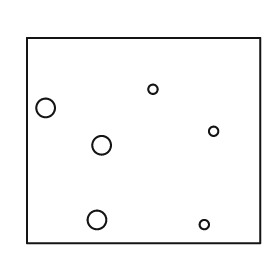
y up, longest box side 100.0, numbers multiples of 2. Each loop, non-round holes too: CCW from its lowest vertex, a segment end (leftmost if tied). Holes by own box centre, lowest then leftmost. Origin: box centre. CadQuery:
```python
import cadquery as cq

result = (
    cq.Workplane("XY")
    .moveTo(-50.0, -44.0)
    .lineTo(50.0, -44.0)
    .lineTo(50.0, 44.0)
    .lineTo(-50.0, 44.0)
    .close()
    .moveTo(26.0, -36.0)
    .circle(2.0)
    .moveTo(-20.0, -34.0)
    .circle(4.0)
    .moveTo(-18.0, -2.0)
    .circle(4.0)
    .moveTo(30.0, 4.0)
    .circle(2.0)
    .moveTo(-42.0, 14.0)
    .circle(4.0)
    .moveTo(4.0, 22.0)
    .circle(2.0)
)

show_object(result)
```